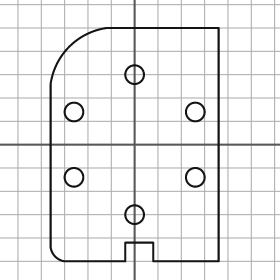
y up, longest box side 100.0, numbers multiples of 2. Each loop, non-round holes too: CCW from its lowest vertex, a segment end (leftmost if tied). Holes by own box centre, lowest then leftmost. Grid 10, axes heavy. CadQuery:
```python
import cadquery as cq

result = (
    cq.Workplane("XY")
    .moveTo(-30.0, -50.0)
    .lineTo(-4.0, -50.0)
    .lineTo(-4.0, -42.0)
    .lineTo(8.0, -42.0)
    .lineTo(8.0, -50.0)
    .lineTo(36.0, -50.0)
    .lineTo(36.0, 50.0)
    .lineTo(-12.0, 50.0)
    .threePointArc((-28.0, 42.0), (-36.0, 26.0))
    .lineTo(-36.0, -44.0)
    .threePointArc((-34.0, -48.0), (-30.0, -50.0))
    .close()
    .moveTo(0.0, -30.0)
    .circle(4.0)
    .moveTo(-26.0, -14.0)
    .circle(4.0)
    .moveTo(26.0, -14.0)
    .circle(4.0)
    .moveTo(-26.0, 14.0)
    .circle(4.0)
    .moveTo(26.0, 14.0)
    .circle(4.0)
    .moveTo(0.0, 30.0)
    .circle(4.0)
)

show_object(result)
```